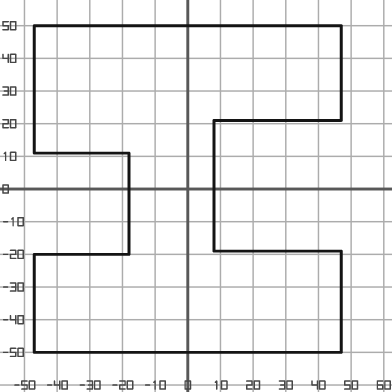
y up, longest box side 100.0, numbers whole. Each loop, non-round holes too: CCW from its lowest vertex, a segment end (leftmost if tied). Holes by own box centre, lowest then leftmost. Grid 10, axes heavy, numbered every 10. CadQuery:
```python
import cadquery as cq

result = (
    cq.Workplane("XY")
    .moveTo(-47.0, -50.0)
    .lineTo(47.0, -50.0)
    .lineTo(47.0, -19.0)
    .lineTo(8.0, -19.0)
    .lineTo(8.0, 21.0)
    .lineTo(47.0, 21.0)
    .lineTo(47.0, 50.0)
    .lineTo(-47.0, 50.0)
    .lineTo(-47.0, 11.0)
    .lineTo(-18.0, 11.0)
    .lineTo(-18.0, -20.0)
    .lineTo(-47.0, -20.0)
    .close()
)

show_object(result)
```